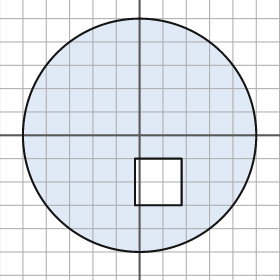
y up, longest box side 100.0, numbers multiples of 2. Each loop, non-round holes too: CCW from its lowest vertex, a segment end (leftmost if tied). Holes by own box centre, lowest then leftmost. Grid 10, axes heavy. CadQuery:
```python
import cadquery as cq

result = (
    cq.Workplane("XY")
    .moveTo(0.0, 0.0)
    .circle(50.0)
    .moveTo(-2.0, -30.0)
    .lineTo(18.0, -30.0)
    .lineTo(18.0, -10.0)
    .lineTo(-2.0, -10.0)
    .close()
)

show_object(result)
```